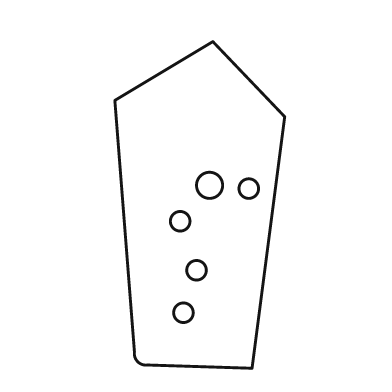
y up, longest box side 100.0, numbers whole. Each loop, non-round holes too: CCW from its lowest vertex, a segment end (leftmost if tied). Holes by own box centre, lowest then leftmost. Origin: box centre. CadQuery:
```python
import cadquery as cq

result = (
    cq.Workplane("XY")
    .moveTo(16.0, -50.0)
    .lineTo(26.0, 27.0)
    .lineTo(4.0, 50.0)
    .lineTo(-26.0, 32.0)
    .lineTo(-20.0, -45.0)
    .threePointArc((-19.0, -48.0), (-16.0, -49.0))
    .close()
    .moveTo(-5.0, -33.0)
    .circle(3.0)
    .moveTo(-1.0, -20.0)
    .circle(3.0)
    .moveTo(-6.0, -5.0)
    .circle(3.0)
    .moveTo(15.0, 5.0)
    .circle(3.0)
    .moveTo(3.0, 6.0)
    .circle(4.0)
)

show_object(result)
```